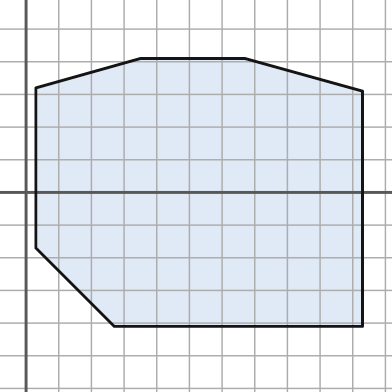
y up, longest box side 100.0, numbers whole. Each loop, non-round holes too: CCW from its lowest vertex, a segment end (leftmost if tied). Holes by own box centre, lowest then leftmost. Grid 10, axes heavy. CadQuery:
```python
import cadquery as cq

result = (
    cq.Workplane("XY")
    .moveTo(27.0, -41.0)
    .lineTo(103.0, -41.0)
    .lineTo(103.0, 31.0)
    .lineTo(67.0, 41.0)
    .lineTo(35.0, 41.0)
    .lineTo(3.0, 32.0)
    .lineTo(3.0, -17.0)
    .close()
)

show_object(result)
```